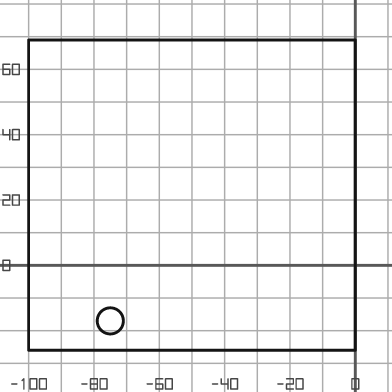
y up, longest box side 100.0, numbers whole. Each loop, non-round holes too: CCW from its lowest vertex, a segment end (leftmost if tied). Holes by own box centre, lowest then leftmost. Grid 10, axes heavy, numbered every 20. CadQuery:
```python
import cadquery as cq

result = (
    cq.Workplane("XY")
    .moveTo(-100.0, -26.0)
    .lineTo(0.0, -26.0)
    .lineTo(0.0, 69.0)
    .lineTo(-100.0, 69.0)
    .close()
    .moveTo(-75.0, -17.0)
    .circle(4.0)
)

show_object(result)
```